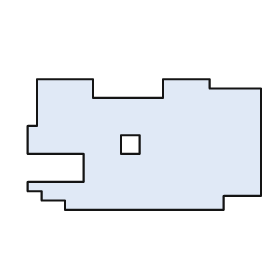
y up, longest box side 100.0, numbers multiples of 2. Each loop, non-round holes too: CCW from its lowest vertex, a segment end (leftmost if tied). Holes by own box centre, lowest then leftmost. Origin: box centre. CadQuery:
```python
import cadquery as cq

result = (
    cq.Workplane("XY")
    .moveTo(-34.0, -28.0)
    .lineTo(34.0, -28.0)
    .lineTo(34.0, -22.0)
    .lineTo(50.0, -22.0)
    .lineTo(50.0, 24.0)
    .lineTo(28.0, 24.0)
    .lineTo(28.0, 28.0)
    .lineTo(8.0, 28.0)
    .lineTo(8.0, 20.0)
    .lineTo(-22.0, 20.0)
    .lineTo(-22.0, 28.0)
    .lineTo(-46.0, 28.0)
    .lineTo(-46.0, 8.0)
    .lineTo(-50.0, 8.0)
    .lineTo(-50.0, -4.0)
    .lineTo(-26.0, -4.0)
    .lineTo(-26.0, -16.0)
    .lineTo(-50.0, -16.0)
    .lineTo(-50.0, -20.0)
    .lineTo(-44.0, -20.0)
    .lineTo(-44.0, -24.0)
    .lineTo(-34.0, -24.0)
    .close()
    .moveTo(-10.0, -4.0)
    .lineTo(-2.0, -4.0)
    .lineTo(-2.0, 4.0)
    .lineTo(-10.0, 4.0)
    .close()
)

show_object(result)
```